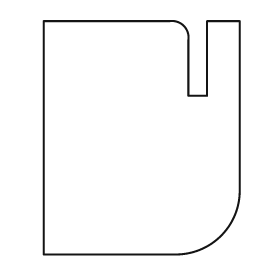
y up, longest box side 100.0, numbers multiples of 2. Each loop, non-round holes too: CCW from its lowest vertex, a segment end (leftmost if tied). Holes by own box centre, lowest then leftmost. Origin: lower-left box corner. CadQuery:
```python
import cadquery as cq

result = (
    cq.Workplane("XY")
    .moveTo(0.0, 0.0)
    .lineTo(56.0, 0.0)
    .threePointArc((76.0, 8.0), (84.0, 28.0))
    .lineTo(84.0, 100.0)
    .lineTo(70.0, 100.0)
    .lineTo(70.0, 68.0)
    .lineTo(62.0, 68.0)
    .lineTo(62.0, 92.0)
    .threePointArc((60.0, 98.0), (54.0, 100.0))
    .lineTo(0.0, 100.0)
    .close()
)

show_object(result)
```